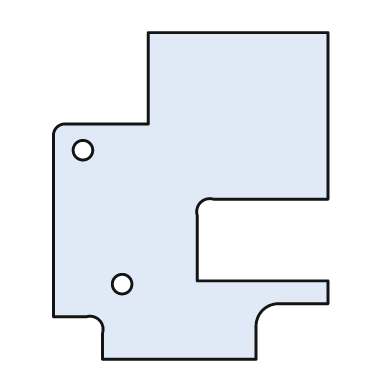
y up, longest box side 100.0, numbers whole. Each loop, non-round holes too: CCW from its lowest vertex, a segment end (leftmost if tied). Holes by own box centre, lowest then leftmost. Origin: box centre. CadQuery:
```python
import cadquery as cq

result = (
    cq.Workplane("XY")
    .moveTo(-27.0, -50.0)
    .lineTo(20.0, -50.0)
    .lineTo(20.0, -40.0)
    .threePointArc((22.0, -35.0), (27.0, -33.0))
    .lineTo(42.0, -33.0)
    .lineTo(42.0, -26.0)
    .lineTo(2.0, -26.0)
    .lineTo(2.0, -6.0)
    .threePointArc((3.0, -2.0), (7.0, -1.0))
    .lineTo(42.0, -1.0)
    .lineTo(42.0, 50.0)
    .lineTo(-13.0, 50.0)
    .lineTo(-13.0, 22.0)
    .lineTo(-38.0, 22.0)
    .threePointArc((-41.0, 21.0), (-42.0, 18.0))
    .lineTo(-42.0, -37.0)
    .lineTo(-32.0, -37.0)
    .threePointArc((-28.0, -38.0), (-27.0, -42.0))
    .close()
    .moveTo(-21.0, -27.0)
    .circle(3.0)
    .moveTo(-33.0, 14.0)
    .circle(3.0)
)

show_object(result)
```